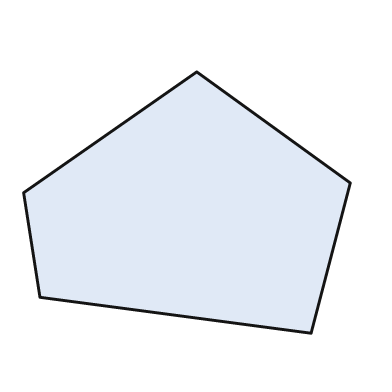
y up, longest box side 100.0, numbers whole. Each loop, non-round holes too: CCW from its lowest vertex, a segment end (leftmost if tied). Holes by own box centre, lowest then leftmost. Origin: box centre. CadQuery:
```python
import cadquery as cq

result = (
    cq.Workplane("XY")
    .moveTo(38.0, -40.0)
    .lineTo(50.0, 6.0)
    .lineTo(3.0, 40.0)
    .lineTo(-50.0, 3.0)
    .lineTo(-45.0, -29.0)
    .close()
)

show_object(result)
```